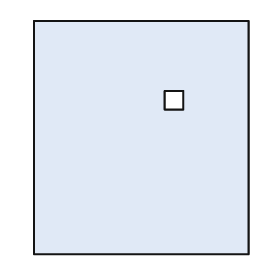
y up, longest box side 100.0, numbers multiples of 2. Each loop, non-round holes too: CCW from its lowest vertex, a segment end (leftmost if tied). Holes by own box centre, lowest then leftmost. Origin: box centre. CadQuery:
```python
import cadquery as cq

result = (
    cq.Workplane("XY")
    .moveTo(-46.0, -50.0)
    .lineTo(46.0, -50.0)
    .lineTo(46.0, 50.0)
    .lineTo(-46.0, 50.0)
    .close()
    .moveTo(10.0, 12.0)
    .lineTo(18.0, 12.0)
    .lineTo(18.0, 20.0)
    .lineTo(10.0, 20.0)
    .close()
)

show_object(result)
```